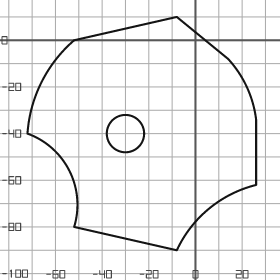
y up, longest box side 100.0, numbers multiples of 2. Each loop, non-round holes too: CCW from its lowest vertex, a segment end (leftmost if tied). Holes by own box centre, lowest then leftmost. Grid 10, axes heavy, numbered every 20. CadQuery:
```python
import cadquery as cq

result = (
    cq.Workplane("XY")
    .moveTo(-8.0, -90.0)
    .threePointArc((6.0, -72.0), (26.0, -62.0))
    .lineTo(26.0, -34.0)
    .threePointArc((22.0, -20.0), (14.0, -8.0))
    .lineTo(-8.0, 10.0)
    .lineTo(-52.0, 0.0)
    .threePointArc((-66.0, -18.0), (-72.0, -40.0))
    .threePointArc((-54.0, -56.0), (-52.0, -80.0))
    .close()
    .moveTo(-30.0, -40.0)
    .circle(8.0)
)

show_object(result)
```